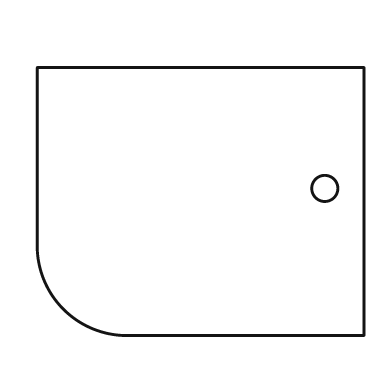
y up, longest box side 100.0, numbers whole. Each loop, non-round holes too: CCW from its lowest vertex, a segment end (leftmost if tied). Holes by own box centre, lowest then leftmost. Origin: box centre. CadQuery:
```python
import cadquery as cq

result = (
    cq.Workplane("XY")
    .moveTo(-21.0, -41.0)
    .lineTo(50.0, -41.0)
    .lineTo(50.0, 41.0)
    .lineTo(-50.0, 41.0)
    .lineTo(-50.0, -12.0)
    .threePointArc((-42.0, -33.0), (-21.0, -41.0))
    .close()
    .moveTo(38.0, 4.0)
    .circle(4.0)
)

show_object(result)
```